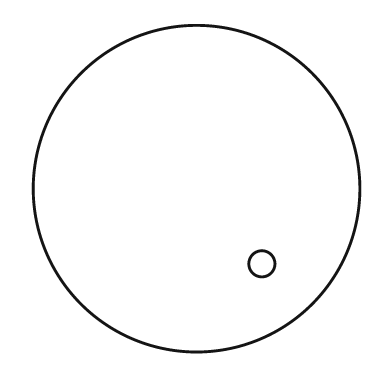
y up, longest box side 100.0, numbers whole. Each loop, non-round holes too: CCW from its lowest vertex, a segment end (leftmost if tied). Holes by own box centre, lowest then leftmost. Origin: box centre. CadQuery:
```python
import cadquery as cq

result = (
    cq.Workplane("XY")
    .moveTo(0.0, 0.0)
    .circle(50.0)
    .moveTo(20.0, -23.0)
    .circle(4.0)
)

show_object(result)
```